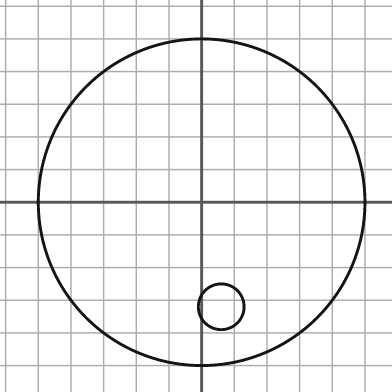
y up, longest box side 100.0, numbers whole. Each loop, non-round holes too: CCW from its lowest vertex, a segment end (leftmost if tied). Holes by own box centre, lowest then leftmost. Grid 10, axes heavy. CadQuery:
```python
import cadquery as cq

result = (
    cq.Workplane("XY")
    .moveTo(0.0, 0.0)
    .circle(50.0)
    .moveTo(6.0, -32.0)
    .circle(7.0)
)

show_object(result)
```